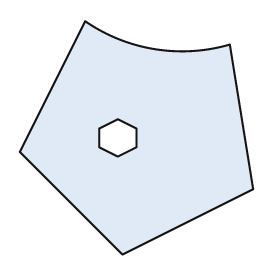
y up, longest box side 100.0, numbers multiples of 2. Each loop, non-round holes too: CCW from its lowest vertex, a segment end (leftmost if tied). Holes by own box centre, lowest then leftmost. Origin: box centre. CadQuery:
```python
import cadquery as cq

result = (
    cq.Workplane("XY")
    .moveTo(-6.0, -50.0)
    .lineTo(50.0, -22.0)
    .lineTo(40.0, 40.0)
    .threePointArc((8.0, 38.0), (-22.0, 50.0))
    .lineTo(-50.0, -6.0)
    .close()
    .moveTo(-8.0, -8.0)
    .lineTo(0.0, -4.0)
    .lineTo(0.0, 4.0)
    .lineTo(-8.0, 8.0)
    .lineTo(-16.0, 4.0)
    .lineTo(-16.0, -4.0)
    .close()
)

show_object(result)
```